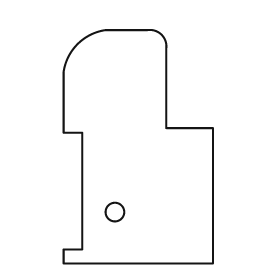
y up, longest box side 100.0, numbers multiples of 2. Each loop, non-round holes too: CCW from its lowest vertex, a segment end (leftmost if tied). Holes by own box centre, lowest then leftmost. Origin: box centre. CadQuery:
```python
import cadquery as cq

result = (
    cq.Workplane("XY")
    .moveTo(-32.0, -50.0)
    .lineTo(32.0, -50.0)
    .lineTo(32.0, 8.0)
    .lineTo(12.0, 8.0)
    .lineTo(12.0, 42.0)
    .threePointArc((10.0, 48.0), (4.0, 50.0))
    .lineTo(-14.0, 50.0)
    .threePointArc((-26.0, 44.0), (-32.0, 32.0))
    .lineTo(-32.0, 6.0)
    .lineTo(-24.0, 6.0)
    .lineTo(-24.0, -44.0)
    .lineTo(-32.0, -44.0)
    .close()
    .moveTo(-10.0, -28.0)
    .circle(4.0)
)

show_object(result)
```